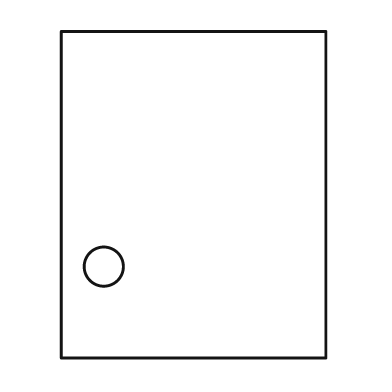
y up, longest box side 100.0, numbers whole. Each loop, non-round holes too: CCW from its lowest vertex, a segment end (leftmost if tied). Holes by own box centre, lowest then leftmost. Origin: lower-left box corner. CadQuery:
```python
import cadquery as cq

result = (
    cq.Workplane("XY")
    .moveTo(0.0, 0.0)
    .lineTo(81.0, 0.0)
    .lineTo(81.0, 100.0)
    .lineTo(0.0, 100.0)
    .close()
    .moveTo(13.0, 28.0)
    .circle(6.0)
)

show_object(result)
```